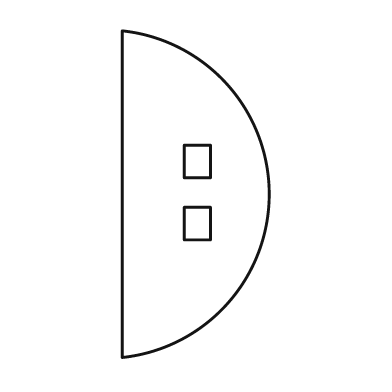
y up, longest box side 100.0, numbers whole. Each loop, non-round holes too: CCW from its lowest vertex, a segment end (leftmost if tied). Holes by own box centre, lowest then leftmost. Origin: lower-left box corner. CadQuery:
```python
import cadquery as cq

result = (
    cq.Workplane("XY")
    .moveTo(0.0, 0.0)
    .threePointArc((45.0, 50.0), (0.0, 100.0))
    .close()
    .moveTo(19.0, 36.0)
    .lineTo(27.0, 36.0)
    .lineTo(27.0, 46.0)
    .lineTo(19.0, 46.0)
    .close()
    .moveTo(19.0, 55.0)
    .lineTo(27.0, 55.0)
    .lineTo(27.0, 65.0)
    .lineTo(19.0, 65.0)
    .close()
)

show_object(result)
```